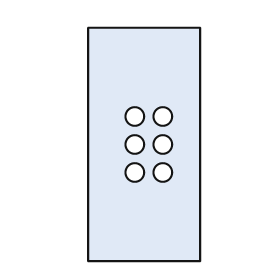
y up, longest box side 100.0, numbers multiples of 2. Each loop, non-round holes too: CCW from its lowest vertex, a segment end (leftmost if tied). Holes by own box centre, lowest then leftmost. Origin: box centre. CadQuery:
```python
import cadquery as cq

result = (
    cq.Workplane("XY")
    .moveTo(-24.0, -50.0)
    .lineTo(24.0, -50.0)
    .lineTo(24.0, 50.0)
    .lineTo(-24.0, 50.0)
    .close()
    .moveTo(-4.0, -12.0)
    .circle(4.0)
    .moveTo(8.0, -12.0)
    .circle(4.0)
    .moveTo(-4.0, 0.0)
    .circle(4.0)
    .moveTo(8.0, 0.0)
    .circle(4.0)
    .moveTo(-4.0, 12.0)
    .circle(4.0)
    .moveTo(8.0, 12.0)
    .circle(4.0)
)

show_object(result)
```